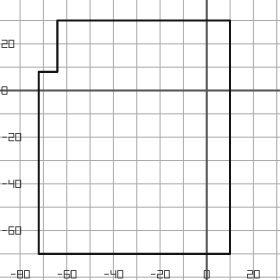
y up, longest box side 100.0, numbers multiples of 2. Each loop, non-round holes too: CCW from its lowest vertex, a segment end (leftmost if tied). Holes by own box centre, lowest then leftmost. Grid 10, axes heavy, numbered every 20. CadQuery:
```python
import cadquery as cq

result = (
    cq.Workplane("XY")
    .moveTo(-72.0, -70.0)
    .lineTo(10.0, -70.0)
    .lineTo(10.0, 30.0)
    .lineTo(-64.0, 30.0)
    .lineTo(-64.0, 8.0)
    .lineTo(-72.0, 8.0)
    .close()
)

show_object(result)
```